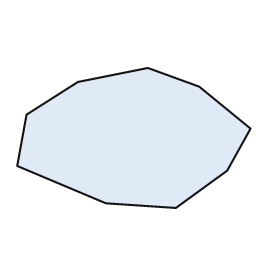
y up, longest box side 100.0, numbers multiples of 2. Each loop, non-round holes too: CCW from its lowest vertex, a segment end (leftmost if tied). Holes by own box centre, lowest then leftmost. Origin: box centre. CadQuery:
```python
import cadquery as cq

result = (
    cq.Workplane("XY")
    .moveTo(18.0, -30.0)
    .lineTo(40.0, -14.0)
    .lineTo(50.0, 4.0)
    .lineTo(28.0, 22.0)
    .lineTo(6.0, 30.0)
    .lineTo(-24.0, 24.0)
    .lineTo(-46.0, 10.0)
    .lineTo(-50.0, -12.0)
    .lineTo(-12.0, -28.0)
    .close()
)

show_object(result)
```